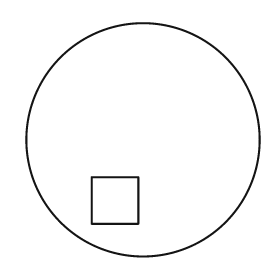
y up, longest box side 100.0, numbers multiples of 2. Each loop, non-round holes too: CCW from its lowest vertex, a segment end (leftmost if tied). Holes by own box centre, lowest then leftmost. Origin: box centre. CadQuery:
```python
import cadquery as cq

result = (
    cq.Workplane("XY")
    .moveTo(0.0, 0.0)
    .circle(50.0)
    .moveTo(-22.0, -36.0)
    .lineTo(-2.0, -36.0)
    .lineTo(-2.0, -16.0)
    .lineTo(-22.0, -16.0)
    .close()
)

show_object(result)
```